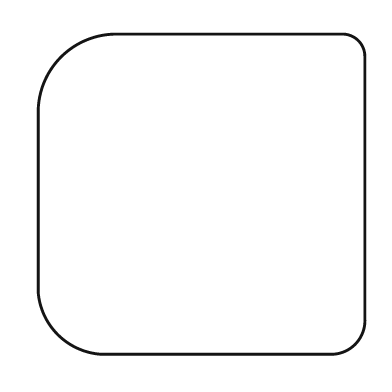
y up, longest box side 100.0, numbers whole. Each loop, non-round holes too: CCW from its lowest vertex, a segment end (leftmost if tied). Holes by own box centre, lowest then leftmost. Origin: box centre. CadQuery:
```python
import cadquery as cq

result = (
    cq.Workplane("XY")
    .moveTo(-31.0, -49.0)
    .lineTo(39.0, -49.0)
    .threePointArc((47.0, -46.0), (50.0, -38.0))
    .lineTo(50.0, 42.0)
    .threePointArc((48.0, 47.0), (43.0, 49.0))
    .lineTo(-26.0, 49.0)
    .threePointArc((-43.0, 42.0), (-50.0, 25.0))
    .lineTo(-50.0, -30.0)
    .threePointArc((-44.0, -43.0), (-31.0, -49.0))
    .close()
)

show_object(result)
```